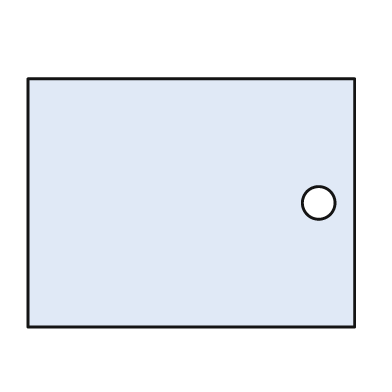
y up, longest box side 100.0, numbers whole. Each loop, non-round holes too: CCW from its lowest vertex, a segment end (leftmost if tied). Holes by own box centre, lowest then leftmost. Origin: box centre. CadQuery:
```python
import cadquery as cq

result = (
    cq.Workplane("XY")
    .moveTo(-50.0, -38.0)
    .lineTo(50.0, -38.0)
    .lineTo(50.0, 38.0)
    .lineTo(-50.0, 38.0)
    .close()
    .moveTo(39.0, 0.0)
    .circle(5.0)
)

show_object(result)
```